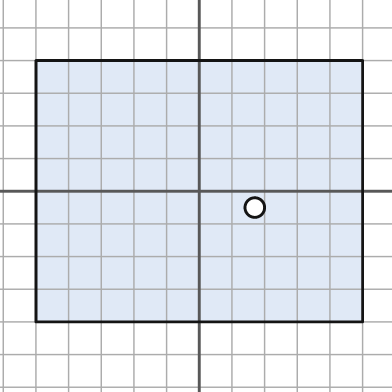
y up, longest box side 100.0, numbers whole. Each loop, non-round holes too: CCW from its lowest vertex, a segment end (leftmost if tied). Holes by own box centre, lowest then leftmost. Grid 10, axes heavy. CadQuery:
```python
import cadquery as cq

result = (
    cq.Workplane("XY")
    .moveTo(-50.0, -40.0)
    .lineTo(50.0, -40.0)
    .lineTo(50.0, 40.0)
    .lineTo(-50.0, 40.0)
    .close()
    .moveTo(17.0, -5.0)
    .circle(3.0)
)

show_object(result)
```